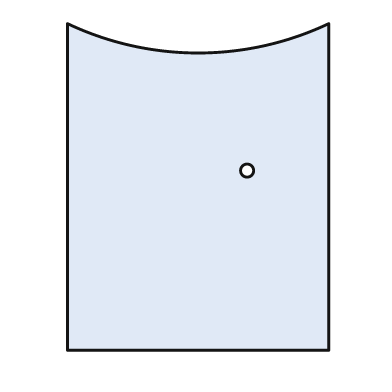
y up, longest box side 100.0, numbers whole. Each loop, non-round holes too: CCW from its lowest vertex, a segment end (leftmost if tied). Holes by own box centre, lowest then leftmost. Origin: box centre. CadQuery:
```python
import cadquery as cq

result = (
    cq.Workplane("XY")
    .moveTo(-40.0, -50.0)
    .lineTo(40.0, -50.0)
    .lineTo(40.0, 50.0)
    .threePointArc((0.0, 41.0), (-40.0, 50.0))
    .close()
    .moveTo(15.0, 5.0)
    .circle(2.0)
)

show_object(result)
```